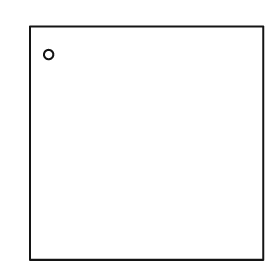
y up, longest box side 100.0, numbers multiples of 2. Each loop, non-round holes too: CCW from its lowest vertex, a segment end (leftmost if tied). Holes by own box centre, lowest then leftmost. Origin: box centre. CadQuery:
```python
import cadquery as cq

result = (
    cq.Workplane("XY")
    .moveTo(-50.0, -50.0)
    .lineTo(50.0, -50.0)
    .lineTo(50.0, 50.0)
    .lineTo(-50.0, 50.0)
    .close()
    .moveTo(-42.0, 38.0)
    .circle(2.0)
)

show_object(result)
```